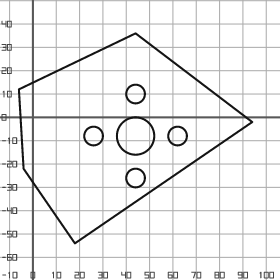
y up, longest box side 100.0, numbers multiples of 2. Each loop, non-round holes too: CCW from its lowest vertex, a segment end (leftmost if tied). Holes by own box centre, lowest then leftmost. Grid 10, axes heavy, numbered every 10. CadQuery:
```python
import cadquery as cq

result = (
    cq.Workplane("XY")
    .moveTo(18.0, -54.0)
    .lineTo(94.0, -2.0)
    .lineTo(44.0, 36.0)
    .lineTo(-6.0, 12.0)
    .lineTo(-4.0, -22.0)
    .close()
    .moveTo(44.0, -26.0)
    .circle(4.0)
    .moveTo(26.0, -8.0)
    .circle(4.0)
    .moveTo(44.0, -8.0)
    .circle(8.0)
    .moveTo(62.0, -8.0)
    .circle(4.0)
    .moveTo(44.0, 10.0)
    .circle(4.0)
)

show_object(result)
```